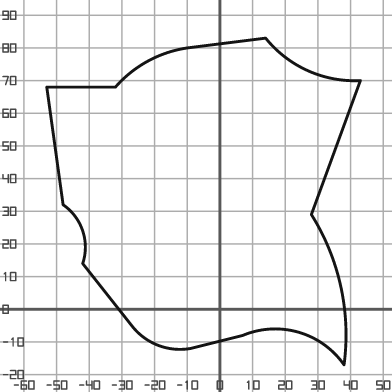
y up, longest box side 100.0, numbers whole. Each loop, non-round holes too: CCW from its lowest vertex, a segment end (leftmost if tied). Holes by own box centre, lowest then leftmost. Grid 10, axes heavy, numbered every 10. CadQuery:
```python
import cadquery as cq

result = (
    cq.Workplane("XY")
    .moveTo(38.0, -17.0)
    .threePointArc((37.0, 7.0), (28.0, 29.0))
    .lineTo(43.0, 70.0)
    .threePointArc((27.0, 73.0), (14.0, 83.0))
    .lineTo(-10.0, 80.0)
    .threePointArc((-22.0, 76.0), (-32.0, 68.0))
    .lineTo(-53.0, 68.0)
    .lineTo(-48.0, 32.0)
    .threePointArc((-42.0, 24.0), (-42.0, 14.0))
    .lineTo(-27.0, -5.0)
    .threePointArc((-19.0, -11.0), (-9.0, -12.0))
    .lineTo(7.0, -8.0)
    .threePointArc((24.0, -7.0), (38.0, -17.0))
    .close()
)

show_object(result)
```